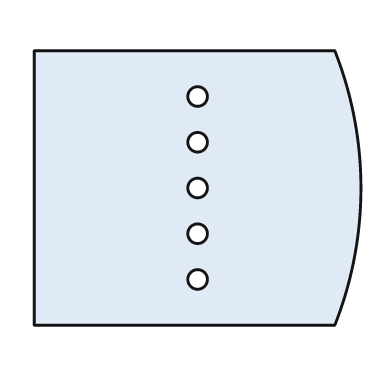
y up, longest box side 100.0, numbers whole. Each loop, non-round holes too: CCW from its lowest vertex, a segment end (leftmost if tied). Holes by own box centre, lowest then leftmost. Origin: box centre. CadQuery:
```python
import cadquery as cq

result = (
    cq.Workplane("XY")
    .moveTo(-50.0, -42.0)
    .lineTo(42.0, -42.0)
    .threePointArc((50.0, 0.0), (42.0, 42.0))
    .lineTo(-50.0, 42.0)
    .close()
    .moveTo(0.0, -28.0)
    .circle(3.0)
    .moveTo(0.0, -14.0)
    .circle(3.0)
    .moveTo(0.0, 0.0)
    .circle(3.0)
    .moveTo(0.0, 14.0)
    .circle(3.0)
    .moveTo(0.0, 28.0)
    .circle(3.0)
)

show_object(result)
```